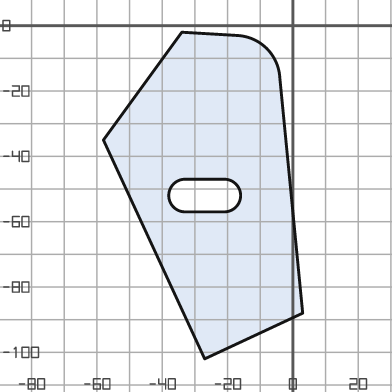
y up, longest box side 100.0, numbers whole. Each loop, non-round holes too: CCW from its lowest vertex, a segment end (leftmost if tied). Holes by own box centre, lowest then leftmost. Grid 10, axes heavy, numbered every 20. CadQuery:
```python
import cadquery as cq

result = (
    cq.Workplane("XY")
    .moveTo(-27.0, -102.0)
    .lineTo(3.0, -88.0)
    .lineTo(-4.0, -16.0)
    .threePointArc((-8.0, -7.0), (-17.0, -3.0))
    .lineTo(-34.0, -2.0)
    .lineTo(-58.0, -35.0)
    .close()
    .moveTo(-33.0, -57.0)
    .lineTo(-21.0, -57.0)
    .threePointArc((-16.0, -52.0), (-21.0, -47.0))
    .lineTo(-33.0, -47.0)
    .threePointArc((-38.0, -52.0), (-33.0, -57.0))
    .close()
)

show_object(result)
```